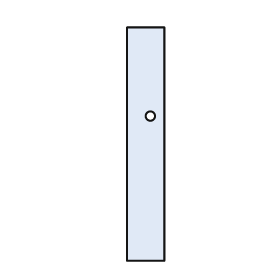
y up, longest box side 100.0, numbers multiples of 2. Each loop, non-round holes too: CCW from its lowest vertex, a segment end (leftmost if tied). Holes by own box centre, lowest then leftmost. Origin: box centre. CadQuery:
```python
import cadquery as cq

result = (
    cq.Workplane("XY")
    .moveTo(-8.0, -50.0)
    .lineTo(8.0, -50.0)
    .lineTo(8.0, 50.0)
    .lineTo(-8.0, 50.0)
    .close()
    .moveTo(2.0, 12.0)
    .circle(2.0)
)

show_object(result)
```